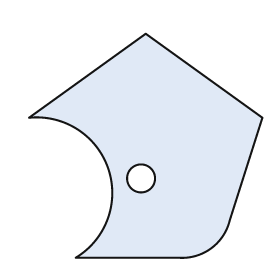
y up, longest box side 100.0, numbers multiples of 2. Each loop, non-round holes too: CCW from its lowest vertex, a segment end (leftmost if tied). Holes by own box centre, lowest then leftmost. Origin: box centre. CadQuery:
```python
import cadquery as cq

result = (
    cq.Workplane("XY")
    .moveTo(-30.0, -48.0)
    .lineTo(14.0, -48.0)
    .threePointArc((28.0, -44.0), (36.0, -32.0))
    .lineTo(50.0, 12.0)
    .lineTo(0.0, 48.0)
    .lineTo(-50.0, 12.0)
    .threePointArc((-16.0, -10.0), (-30.0, -48.0))
    .close()
    .moveTo(-2.0, -14.0)
    .circle(6.0)
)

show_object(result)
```